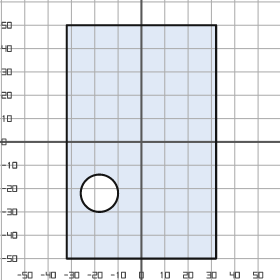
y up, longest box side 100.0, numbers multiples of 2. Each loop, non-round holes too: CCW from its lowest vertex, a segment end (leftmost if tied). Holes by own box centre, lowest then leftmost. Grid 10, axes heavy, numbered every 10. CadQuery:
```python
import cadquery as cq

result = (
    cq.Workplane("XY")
    .moveTo(-32.0, -50.0)
    .lineTo(32.0, -50.0)
    .lineTo(32.0, 50.0)
    .lineTo(-32.0, 50.0)
    .close()
    .moveTo(-18.0, -22.0)
    .circle(8.0)
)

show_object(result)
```